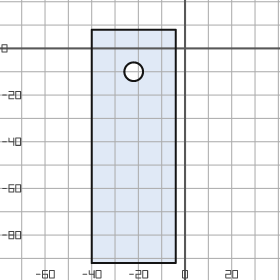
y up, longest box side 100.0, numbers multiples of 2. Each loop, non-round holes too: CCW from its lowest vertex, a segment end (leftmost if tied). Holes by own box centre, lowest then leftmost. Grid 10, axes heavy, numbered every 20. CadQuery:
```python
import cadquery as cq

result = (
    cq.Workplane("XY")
    .moveTo(-40.0, -92.0)
    .lineTo(-4.0, -92.0)
    .lineTo(-4.0, 8.0)
    .lineTo(-40.0, 8.0)
    .close()
    .moveTo(-22.0, -10.0)
    .circle(4.0)
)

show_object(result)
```